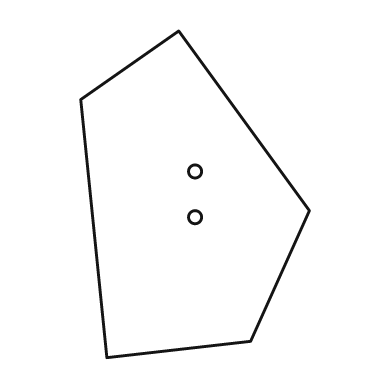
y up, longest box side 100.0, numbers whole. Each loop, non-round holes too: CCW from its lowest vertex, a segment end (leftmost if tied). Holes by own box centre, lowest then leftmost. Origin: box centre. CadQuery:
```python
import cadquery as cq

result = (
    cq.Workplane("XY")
    .moveTo(-27.0, -50.0)
    .lineTo(17.0, -45.0)
    .lineTo(35.0, -5.0)
    .lineTo(-5.0, 50.0)
    .lineTo(-35.0, 29.0)
    .close()
    .moveTo(0.0, -7.0)
    .circle(2.0)
    .moveTo(0.0, 7.0)
    .circle(2.0)
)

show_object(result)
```